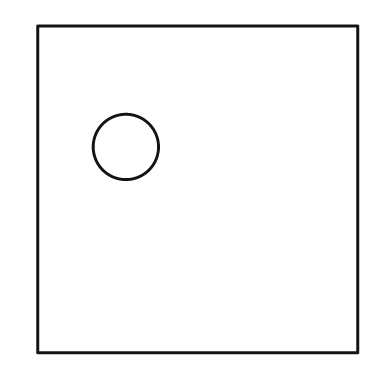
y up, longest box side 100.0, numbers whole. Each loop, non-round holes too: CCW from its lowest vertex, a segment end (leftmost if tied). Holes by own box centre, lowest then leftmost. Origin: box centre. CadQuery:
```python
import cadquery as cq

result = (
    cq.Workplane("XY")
    .moveTo(-49.0, -50.0)
    .lineTo(49.0, -50.0)
    .lineTo(49.0, 50.0)
    .lineTo(-49.0, 50.0)
    .close()
    .moveTo(-22.0, 13.0)
    .circle(10.0)
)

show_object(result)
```